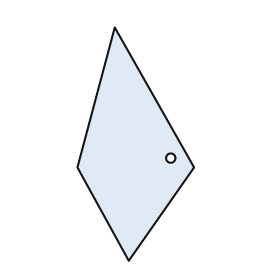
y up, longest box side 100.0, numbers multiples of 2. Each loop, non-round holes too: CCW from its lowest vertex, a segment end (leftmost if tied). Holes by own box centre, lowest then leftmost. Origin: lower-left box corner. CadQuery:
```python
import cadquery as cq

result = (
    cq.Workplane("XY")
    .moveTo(22.0, 0.0)
    .lineTo(50.0, 40.0)
    .lineTo(16.0, 100.0)
    .lineTo(0.0, 40.0)
    .close()
    .moveTo(40.0, 44.0)
    .circle(2.0)
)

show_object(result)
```